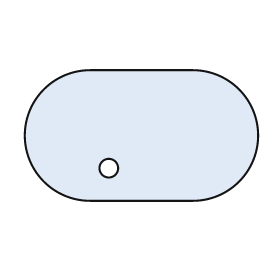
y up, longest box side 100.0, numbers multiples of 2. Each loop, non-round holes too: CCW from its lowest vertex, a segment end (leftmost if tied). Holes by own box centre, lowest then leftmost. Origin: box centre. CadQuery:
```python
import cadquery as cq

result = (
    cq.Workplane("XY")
    .moveTo(-22.0, -28.0)
    .lineTo(22.0, -28.0)
    .threePointArc((50.0, 0.0), (22.0, 28.0))
    .lineTo(-22.0, 28.0)
    .threePointArc((-50.0, 0.0), (-22.0, -28.0))
    .close()
    .moveTo(-14.0, -14.0)
    .circle(4.0)
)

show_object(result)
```